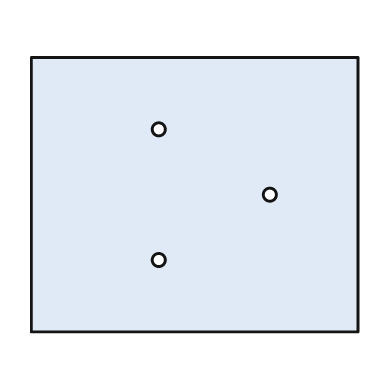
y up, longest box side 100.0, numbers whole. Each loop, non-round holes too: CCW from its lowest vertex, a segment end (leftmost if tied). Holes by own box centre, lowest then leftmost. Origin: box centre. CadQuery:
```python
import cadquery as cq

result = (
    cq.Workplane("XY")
    .moveTo(-50.0, -42.0)
    .lineTo(50.0, -42.0)
    .lineTo(50.0, 42.0)
    .lineTo(-50.0, 42.0)
    .close()
    .moveTo(-11.0, -20.0)
    .circle(2.0)
    .moveTo(23.0, 0.0)
    .circle(2.0)
    .moveTo(-11.0, 20.0)
    .circle(2.0)
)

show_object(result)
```